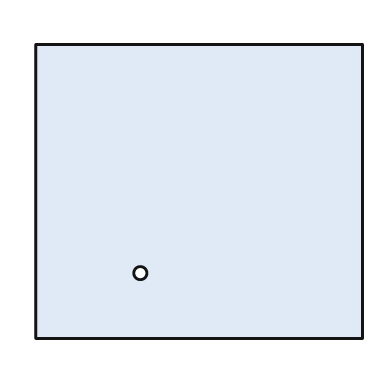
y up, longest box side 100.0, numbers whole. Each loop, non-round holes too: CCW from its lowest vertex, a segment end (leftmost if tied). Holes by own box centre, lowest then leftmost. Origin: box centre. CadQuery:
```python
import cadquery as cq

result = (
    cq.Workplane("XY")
    .moveTo(-50.0, -45.0)
    .lineTo(50.0, -45.0)
    .lineTo(50.0, 45.0)
    .lineTo(-50.0, 45.0)
    .close()
    .moveTo(-18.0, -25.0)
    .circle(2.0)
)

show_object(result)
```